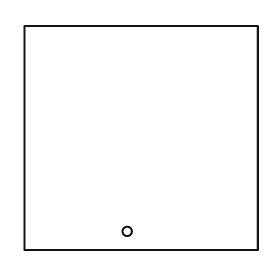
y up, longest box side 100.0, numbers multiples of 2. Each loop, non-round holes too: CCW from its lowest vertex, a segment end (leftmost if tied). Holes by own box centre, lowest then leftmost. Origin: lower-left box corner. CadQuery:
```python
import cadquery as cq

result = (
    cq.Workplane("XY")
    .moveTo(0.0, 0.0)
    .lineTo(100.0, 0.0)
    .lineTo(100.0, 96.0)
    .lineTo(0.0, 96.0)
    .close()
    .moveTo(44.0, 8.0)
    .circle(2.0)
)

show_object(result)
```